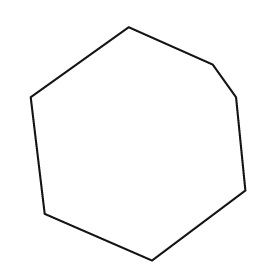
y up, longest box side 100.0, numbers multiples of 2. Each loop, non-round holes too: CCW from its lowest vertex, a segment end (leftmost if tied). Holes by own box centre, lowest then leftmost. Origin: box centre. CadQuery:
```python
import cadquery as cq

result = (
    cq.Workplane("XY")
    .moveTo(6.0, -50.0)
    .lineTo(46.0, -20.0)
    .lineTo(42.0, 20.0)
    .lineTo(32.0, 34.0)
    .lineTo(-4.0, 50.0)
    .lineTo(-46.0, 20.0)
    .lineTo(-40.0, -30.0)
    .close()
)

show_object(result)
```